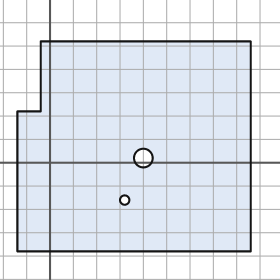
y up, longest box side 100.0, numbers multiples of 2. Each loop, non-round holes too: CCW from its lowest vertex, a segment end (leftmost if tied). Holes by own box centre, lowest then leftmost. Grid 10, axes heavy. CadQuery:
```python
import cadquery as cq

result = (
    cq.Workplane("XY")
    .moveTo(-14.0, -38.0)
    .lineTo(86.0, -38.0)
    .lineTo(86.0, 52.0)
    .lineTo(-4.0, 52.0)
    .lineTo(-4.0, 22.0)
    .lineTo(-14.0, 22.0)
    .close()
    .moveTo(32.0, -16.0)
    .circle(2.0)
    .moveTo(40.0, 2.0)
    .circle(4.0)
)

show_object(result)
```